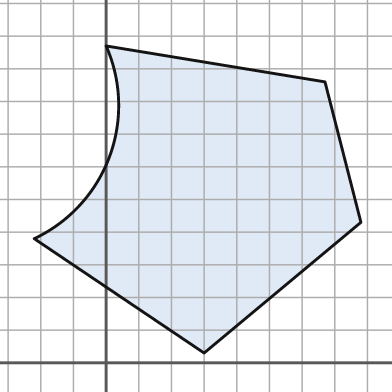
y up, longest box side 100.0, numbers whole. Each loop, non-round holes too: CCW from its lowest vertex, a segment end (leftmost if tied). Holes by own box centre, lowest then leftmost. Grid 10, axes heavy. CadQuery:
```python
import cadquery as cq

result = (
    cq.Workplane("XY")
    .moveTo(30.0, 3.0)
    .lineTo(78.0, 43.0)
    .lineTo(67.0, 86.0)
    .lineTo(0.0, 97.0)
    .threePointArc((1.0, 63.0), (-22.0, 38.0))
    .close()
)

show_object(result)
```